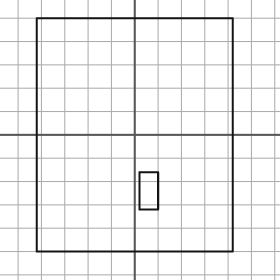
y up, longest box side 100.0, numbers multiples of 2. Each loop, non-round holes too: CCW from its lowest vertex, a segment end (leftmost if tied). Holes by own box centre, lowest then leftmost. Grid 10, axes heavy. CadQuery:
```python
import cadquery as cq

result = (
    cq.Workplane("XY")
    .moveTo(-42.0, -50.0)
    .lineTo(42.0, -50.0)
    .lineTo(42.0, 50.0)
    .lineTo(-42.0, 50.0)
    .close()
    .moveTo(2.0, -32.0)
    .lineTo(10.0, -32.0)
    .lineTo(10.0, -16.0)
    .lineTo(2.0, -16.0)
    .close()
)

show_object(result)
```